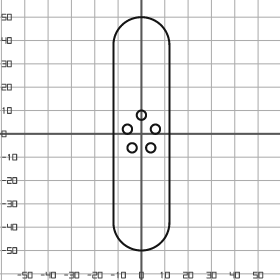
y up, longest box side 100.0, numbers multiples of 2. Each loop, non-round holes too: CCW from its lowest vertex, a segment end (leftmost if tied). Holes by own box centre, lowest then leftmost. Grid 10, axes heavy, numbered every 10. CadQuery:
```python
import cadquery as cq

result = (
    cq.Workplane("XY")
    .moveTo(-12.0, -38.0)
    .threePointArc((0.0, -50.0), (12.0, -38.0))
    .lineTo(12.0, 38.0)
    .threePointArc((0.0, 50.0), (-12.0, 38.0))
    .close()
    .moveTo(-4.0, -6.0)
    .circle(2.0)
    .moveTo(4.0, -6.0)
    .circle(2.0)
    .moveTo(-6.0, 2.0)
    .circle(2.0)
    .moveTo(6.0, 2.0)
    .circle(2.0)
    .moveTo(0.0, 8.0)
    .circle(2.0)
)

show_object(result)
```